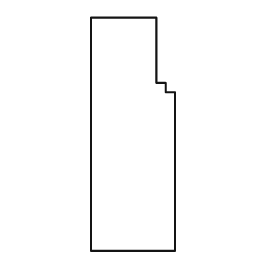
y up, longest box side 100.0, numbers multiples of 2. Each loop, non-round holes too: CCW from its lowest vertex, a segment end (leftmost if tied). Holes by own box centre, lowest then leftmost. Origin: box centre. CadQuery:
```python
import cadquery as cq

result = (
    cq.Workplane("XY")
    .moveTo(-18.0, -50.0)
    .lineTo(18.0, -50.0)
    .lineTo(18.0, 18.0)
    .lineTo(14.0, 18.0)
    .lineTo(14.0, 22.0)
    .lineTo(10.0, 22.0)
    .lineTo(10.0, 50.0)
    .lineTo(-18.0, 50.0)
    .close()
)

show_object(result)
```